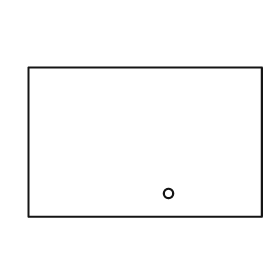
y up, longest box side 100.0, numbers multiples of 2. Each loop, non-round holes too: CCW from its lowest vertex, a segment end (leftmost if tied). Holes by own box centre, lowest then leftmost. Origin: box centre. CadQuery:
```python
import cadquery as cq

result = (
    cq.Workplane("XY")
    .moveTo(-50.0, -32.0)
    .lineTo(50.0, -32.0)
    .lineTo(50.0, 32.0)
    .lineTo(-50.0, 32.0)
    .close()
    .moveTo(10.0, -22.0)
    .circle(2.0)
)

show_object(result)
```